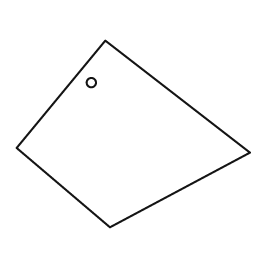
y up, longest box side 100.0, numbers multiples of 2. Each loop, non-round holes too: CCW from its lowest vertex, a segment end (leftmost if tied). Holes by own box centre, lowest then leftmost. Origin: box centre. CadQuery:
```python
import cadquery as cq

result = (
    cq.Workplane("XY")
    .moveTo(-10.0, -40.0)
    .lineTo(50.0, -8.0)
    .lineTo(-12.0, 40.0)
    .lineTo(-50.0, -6.0)
    .close()
    .moveTo(-18.0, 22.0)
    .circle(2.0)
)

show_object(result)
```